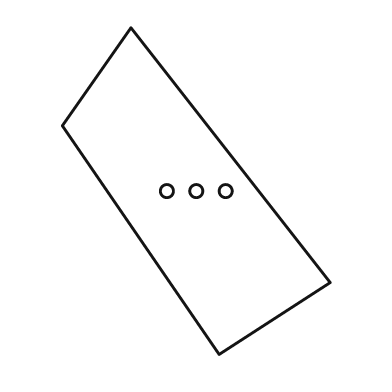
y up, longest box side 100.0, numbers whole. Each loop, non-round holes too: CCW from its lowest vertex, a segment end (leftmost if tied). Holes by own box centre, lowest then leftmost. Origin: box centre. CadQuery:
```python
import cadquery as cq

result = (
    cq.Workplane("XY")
    .moveTo(7.0, -50.0)
    .lineTo(41.0, -28.0)
    .lineTo(-20.0, 50.0)
    .lineTo(-41.0, 20.0)
    .close()
    .moveTo(-9.0, 0.0)
    .circle(2.0)
    .moveTo(0.0, 0.0)
    .circle(2.0)
    .moveTo(9.0, 0.0)
    .circle(2.0)
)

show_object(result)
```